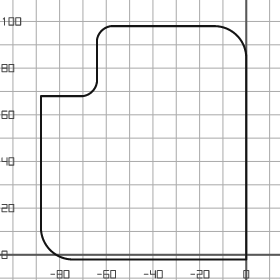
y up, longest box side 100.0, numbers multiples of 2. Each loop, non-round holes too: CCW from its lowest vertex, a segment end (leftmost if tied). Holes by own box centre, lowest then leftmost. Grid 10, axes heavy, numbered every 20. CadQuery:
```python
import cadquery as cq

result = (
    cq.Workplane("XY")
    .moveTo(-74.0, -2.0)
    .lineTo(0.0, -2.0)
    .lineTo(0.0, 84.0)
    .threePointArc((-4.0, 94.0), (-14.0, 98.0))
    .lineTo(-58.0, 98.0)
    .threePointArc((-62.0, 96.0), (-64.0, 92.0))
    .lineTo(-64.0, 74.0)
    .threePointArc((-66.0, 70.0), (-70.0, 68.0))
    .lineTo(-88.0, 68.0)
    .lineTo(-88.0, 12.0)
    .threePointArc((-84.0, 2.0), (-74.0, -2.0))
    .close()
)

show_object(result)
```